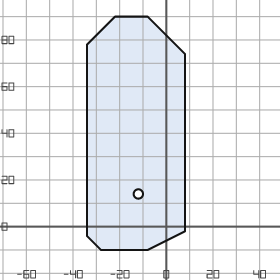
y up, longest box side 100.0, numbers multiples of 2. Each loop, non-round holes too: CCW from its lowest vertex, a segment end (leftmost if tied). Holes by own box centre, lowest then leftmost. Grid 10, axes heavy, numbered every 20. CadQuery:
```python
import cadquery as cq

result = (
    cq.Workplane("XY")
    .moveTo(-28.0, -10.0)
    .lineTo(-8.0, -10.0)
    .lineTo(8.0, -2.0)
    .lineTo(8.0, 74.0)
    .lineTo(-8.0, 90.0)
    .lineTo(-22.0, 90.0)
    .lineTo(-34.0, 78.0)
    .lineTo(-34.0, -4.0)
    .close()
    .moveTo(-12.0, 14.0)
    .circle(2.0)
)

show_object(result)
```